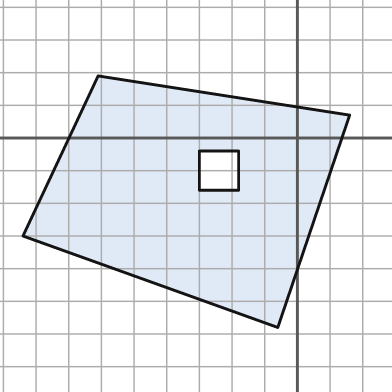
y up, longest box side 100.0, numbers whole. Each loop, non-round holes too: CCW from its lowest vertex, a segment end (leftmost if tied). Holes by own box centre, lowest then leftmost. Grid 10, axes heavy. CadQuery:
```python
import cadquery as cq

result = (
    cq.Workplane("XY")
    .moveTo(-6.0, -58.0)
    .lineTo(16.0, 7.0)
    .lineTo(-61.0, 19.0)
    .lineTo(-84.0, -30.0)
    .close()
    .moveTo(-30.0, -16.0)
    .lineTo(-18.0, -16.0)
    .lineTo(-18.0, -4.0)
    .lineTo(-30.0, -4.0)
    .close()
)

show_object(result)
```